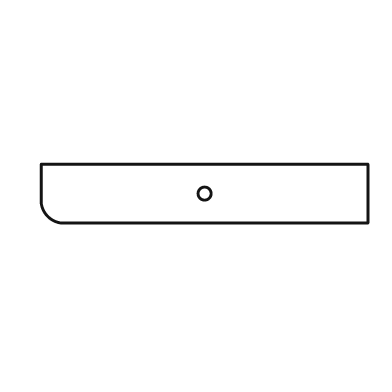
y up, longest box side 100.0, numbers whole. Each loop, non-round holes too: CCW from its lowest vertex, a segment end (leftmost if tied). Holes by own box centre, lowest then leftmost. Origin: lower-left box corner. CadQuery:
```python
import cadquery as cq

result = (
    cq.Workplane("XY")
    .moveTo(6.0, 0.0)
    .lineTo(100.0, 0.0)
    .lineTo(100.0, 18.0)
    .lineTo(0.0, 18.0)
    .lineTo(0.0, 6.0)
    .threePointArc((2.0, 2.0), (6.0, 0.0))
    .close()
    .moveTo(50.0, 9.0)
    .circle(2.0)
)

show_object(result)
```